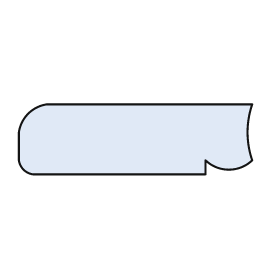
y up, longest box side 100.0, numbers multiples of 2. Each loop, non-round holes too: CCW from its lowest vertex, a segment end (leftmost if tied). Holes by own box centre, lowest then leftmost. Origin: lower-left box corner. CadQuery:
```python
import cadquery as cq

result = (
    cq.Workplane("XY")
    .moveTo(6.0, 0.0)
    .lineTo(80.0, 0.0)
    .lineTo(80.0, 6.0)
    .threePointArc((90.0, 2.0), (100.0, 6.0))
    .threePointArc((98.0, 18.0), (100.0, 30.0))
    .lineTo(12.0, 30.0)
    .threePointArc((4.0, 26.0), (0.0, 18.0))
    .lineTo(0.0, 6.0)
    .threePointArc((2.0, 2.0), (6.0, 0.0))
    .close()
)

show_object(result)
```